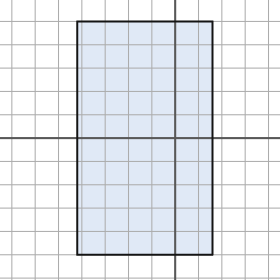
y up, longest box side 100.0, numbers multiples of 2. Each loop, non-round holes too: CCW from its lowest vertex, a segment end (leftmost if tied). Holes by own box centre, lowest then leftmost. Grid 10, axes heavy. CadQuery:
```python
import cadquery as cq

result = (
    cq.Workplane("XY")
    .moveTo(-42.0, -50.0)
    .lineTo(16.0, -50.0)
    .lineTo(16.0, 50.0)
    .lineTo(-42.0, 50.0)
    .close()
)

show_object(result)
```